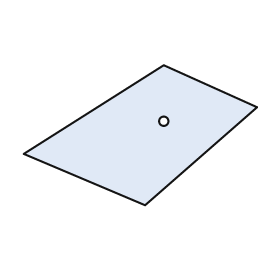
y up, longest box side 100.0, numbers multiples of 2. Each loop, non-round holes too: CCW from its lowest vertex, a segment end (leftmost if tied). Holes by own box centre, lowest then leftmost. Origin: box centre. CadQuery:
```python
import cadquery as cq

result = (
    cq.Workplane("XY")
    .moveTo(2.0, -30.0)
    .lineTo(50.0, 12.0)
    .lineTo(10.0, 30.0)
    .lineTo(-50.0, -8.0)
    .close()
    .moveTo(10.0, 6.0)
    .circle(2.0)
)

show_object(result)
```